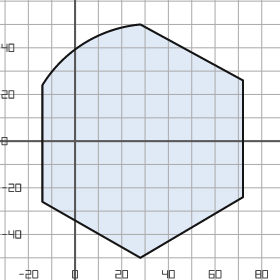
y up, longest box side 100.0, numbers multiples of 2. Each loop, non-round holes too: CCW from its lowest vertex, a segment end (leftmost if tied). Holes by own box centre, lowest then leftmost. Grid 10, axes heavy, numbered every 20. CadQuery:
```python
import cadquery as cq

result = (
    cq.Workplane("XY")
    .moveTo(28.0, -50.0)
    .lineTo(72.0, -24.0)
    .lineTo(72.0, 26.0)
    .lineTo(28.0, 50.0)
    .threePointArc((4.0, 42.0), (-14.0, 24.0))
    .lineTo(-14.0, -26.0)
    .close()
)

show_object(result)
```